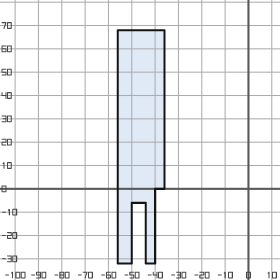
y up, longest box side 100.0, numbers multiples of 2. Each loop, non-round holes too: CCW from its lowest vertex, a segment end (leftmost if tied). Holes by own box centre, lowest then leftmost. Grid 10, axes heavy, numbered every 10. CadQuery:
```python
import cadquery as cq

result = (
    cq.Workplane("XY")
    .moveTo(-56.0, -32.0)
    .lineTo(-50.0, -32.0)
    .lineTo(-50.0, -6.0)
    .lineTo(-44.0, -6.0)
    .lineTo(-44.0, -32.0)
    .lineTo(-40.0, -32.0)
    .lineTo(-40.0, 0.0)
    .lineTo(-36.0, 0.0)
    .lineTo(-36.0, 68.0)
    .lineTo(-56.0, 68.0)
    .close()
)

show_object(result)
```